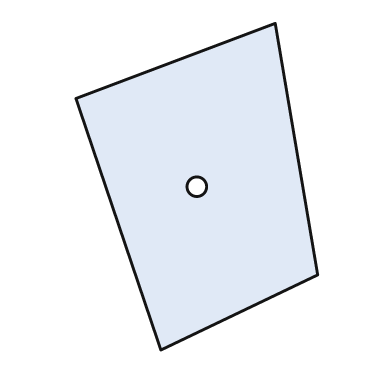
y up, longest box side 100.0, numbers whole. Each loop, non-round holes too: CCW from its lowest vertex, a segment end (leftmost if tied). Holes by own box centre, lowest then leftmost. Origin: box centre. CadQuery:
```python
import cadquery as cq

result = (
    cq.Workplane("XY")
    .moveTo(-11.0, -50.0)
    .lineTo(37.0, -27.0)
    .lineTo(24.0, 50.0)
    .lineTo(-37.0, 27.0)
    .close()
    .moveTo(0.0, 0.0)
    .circle(3.0)
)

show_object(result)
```